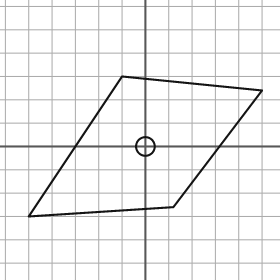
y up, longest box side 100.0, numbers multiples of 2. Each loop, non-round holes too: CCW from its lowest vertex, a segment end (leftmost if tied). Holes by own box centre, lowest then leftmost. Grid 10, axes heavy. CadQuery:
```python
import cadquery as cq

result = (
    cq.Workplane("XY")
    .moveTo(-50.0, -30.0)
    .lineTo(12.0, -26.0)
    .lineTo(50.0, 24.0)
    .lineTo(-10.0, 30.0)
    .close()
    .moveTo(0.0, 0.0)
    .circle(4.0)
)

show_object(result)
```